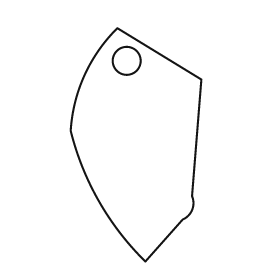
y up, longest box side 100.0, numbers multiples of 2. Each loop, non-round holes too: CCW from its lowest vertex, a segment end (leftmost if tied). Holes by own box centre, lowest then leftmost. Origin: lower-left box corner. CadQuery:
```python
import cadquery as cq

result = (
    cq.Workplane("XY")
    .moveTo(32.0, 0.0)
    .lineTo(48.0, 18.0)
    .threePointArc((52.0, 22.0), (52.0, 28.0))
    .lineTo(56.0, 78.0)
    .lineTo(20.0, 100.0)
    .threePointArc((6.0, 80.0), (0.0, 56.0))
    .threePointArc((12.0, 26.0), (32.0, 0.0))
    .close()
    .moveTo(24.0, 86.0)
    .circle(6.0)
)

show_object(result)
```